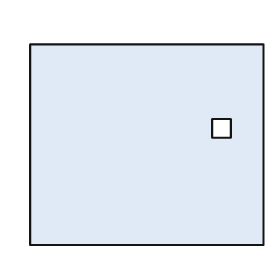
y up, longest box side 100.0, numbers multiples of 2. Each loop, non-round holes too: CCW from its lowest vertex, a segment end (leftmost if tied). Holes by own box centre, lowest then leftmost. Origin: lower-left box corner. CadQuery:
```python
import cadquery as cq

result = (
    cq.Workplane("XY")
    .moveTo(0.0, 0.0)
    .lineTo(100.0, 0.0)
    .lineTo(100.0, 86.0)
    .lineTo(0.0, 86.0)
    .close()
    .moveTo(78.0, 46.0)
    .lineTo(86.0, 46.0)
    .lineTo(86.0, 54.0)
    .lineTo(78.0, 54.0)
    .close()
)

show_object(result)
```